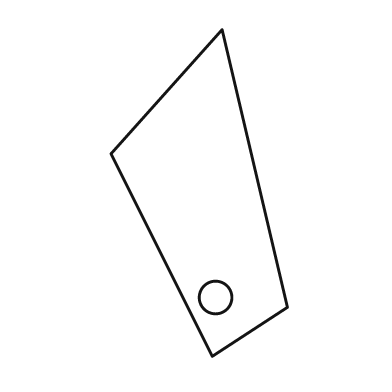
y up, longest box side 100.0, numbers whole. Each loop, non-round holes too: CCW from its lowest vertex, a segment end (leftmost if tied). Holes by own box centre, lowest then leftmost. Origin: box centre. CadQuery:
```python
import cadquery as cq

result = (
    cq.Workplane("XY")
    .moveTo(4.0, -50.0)
    .lineTo(27.0, -35.0)
    .lineTo(7.0, 50.0)
    .lineTo(-27.0, 12.0)
    .close()
    .moveTo(5.0, -32.0)
    .circle(5.0)
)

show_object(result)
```